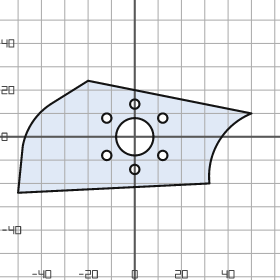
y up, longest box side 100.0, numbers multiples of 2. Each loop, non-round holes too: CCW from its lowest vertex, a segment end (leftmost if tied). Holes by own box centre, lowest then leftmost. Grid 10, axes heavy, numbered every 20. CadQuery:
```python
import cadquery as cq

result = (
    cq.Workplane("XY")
    .moveTo(-50.0, -24.0)
    .lineTo(32.0, -20.0)
    .threePointArc((36.0, -2.0), (50.0, 10.0))
    .lineTo(-20.0, 24.0)
    .lineTo(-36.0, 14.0)
    .threePointArc((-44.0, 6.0), (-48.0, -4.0))
    .close()
    .moveTo(0.0, -14.0)
    .circle(2.0)
    .moveTo(-12.0, -8.0)
    .circle(2.0)
    .moveTo(12.0, -8.0)
    .circle(2.0)
    .moveTo(0.0, 0.0)
    .circle(8.0)
    .moveTo(-12.0, 8.0)
    .circle(2.0)
    .moveTo(12.0, 8.0)
    .circle(2.0)
    .moveTo(0.0, 14.0)
    .circle(2.0)
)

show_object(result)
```